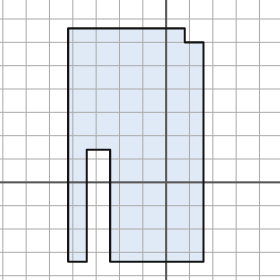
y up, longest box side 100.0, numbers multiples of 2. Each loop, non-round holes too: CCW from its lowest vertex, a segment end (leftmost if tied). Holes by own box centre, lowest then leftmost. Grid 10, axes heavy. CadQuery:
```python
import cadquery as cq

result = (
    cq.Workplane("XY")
    .moveTo(-42.0, -34.0)
    .lineTo(-34.0, -34.0)
    .lineTo(-34.0, 14.0)
    .lineTo(-24.0, 14.0)
    .lineTo(-24.0, -34.0)
    .lineTo(16.0, -34.0)
    .lineTo(16.0, 60.0)
    .lineTo(8.0, 60.0)
    .lineTo(8.0, 66.0)
    .lineTo(-42.0, 66.0)
    .close()
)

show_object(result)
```